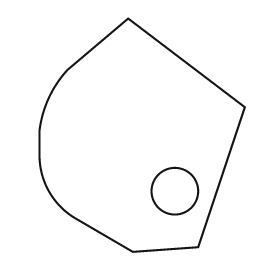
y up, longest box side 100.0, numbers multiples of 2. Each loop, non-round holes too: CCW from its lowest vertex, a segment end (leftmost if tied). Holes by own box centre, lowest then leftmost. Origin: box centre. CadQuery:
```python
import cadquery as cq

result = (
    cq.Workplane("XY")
    .moveTo(-4.0, -50.0)
    .lineTo(24.0, -48.0)
    .lineTo(44.0, 12.0)
    .lineTo(-6.0, 50.0)
    .lineTo(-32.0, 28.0)
    .threePointArc((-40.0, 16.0), (-44.0, 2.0))
    .lineTo(-44.0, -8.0)
    .threePointArc((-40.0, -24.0), (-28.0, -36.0))
    .close()
    .moveTo(14.0, -24.0)
    .circle(10.0)
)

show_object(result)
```